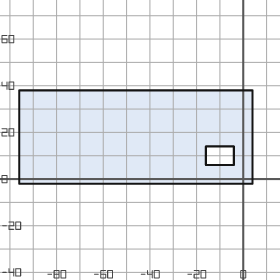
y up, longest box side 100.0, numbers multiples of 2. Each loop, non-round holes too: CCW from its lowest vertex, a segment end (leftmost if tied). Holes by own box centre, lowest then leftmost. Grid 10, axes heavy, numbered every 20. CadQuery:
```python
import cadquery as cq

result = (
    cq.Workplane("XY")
    .moveTo(-96.0, -2.0)
    .lineTo(4.0, -2.0)
    .lineTo(4.0, 38.0)
    .lineTo(-96.0, 38.0)
    .close()
    .moveTo(-16.0, 6.0)
    .lineTo(-4.0, 6.0)
    .lineTo(-4.0, 14.0)
    .lineTo(-16.0, 14.0)
    .close()
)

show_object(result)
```